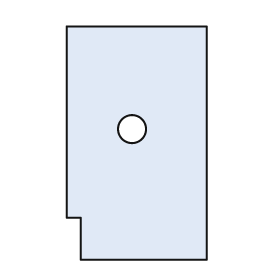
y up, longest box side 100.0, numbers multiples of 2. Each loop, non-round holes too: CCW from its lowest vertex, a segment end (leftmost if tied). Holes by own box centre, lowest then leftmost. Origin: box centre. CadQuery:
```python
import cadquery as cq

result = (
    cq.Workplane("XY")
    .moveTo(-24.0, -50.0)
    .lineTo(30.0, -50.0)
    .lineTo(30.0, 50.0)
    .lineTo(-30.0, 50.0)
    .lineTo(-30.0, -32.0)
    .lineTo(-24.0, -32.0)
    .close()
    .moveTo(-2.0, 6.0)
    .circle(6.0)
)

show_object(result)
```